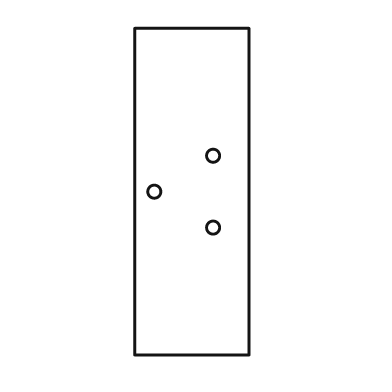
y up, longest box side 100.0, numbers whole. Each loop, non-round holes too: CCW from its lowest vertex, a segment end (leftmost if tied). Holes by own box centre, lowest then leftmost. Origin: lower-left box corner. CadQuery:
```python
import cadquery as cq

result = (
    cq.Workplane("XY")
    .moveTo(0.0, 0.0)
    .lineTo(35.0, 0.0)
    .lineTo(35.0, 100.0)
    .lineTo(0.0, 100.0)
    .close()
    .moveTo(24.0, 39.0)
    .circle(2.0)
    .moveTo(6.0, 50.0)
    .circle(2.0)
    .moveTo(24.0, 61.0)
    .circle(2.0)
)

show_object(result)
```